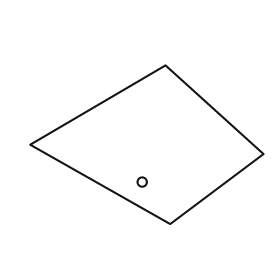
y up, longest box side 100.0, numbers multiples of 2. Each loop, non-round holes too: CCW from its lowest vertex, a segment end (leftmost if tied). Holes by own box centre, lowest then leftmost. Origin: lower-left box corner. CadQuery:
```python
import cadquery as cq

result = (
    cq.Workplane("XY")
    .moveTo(60.0, 0.0)
    .lineTo(100.0, 30.0)
    .lineTo(58.0, 68.0)
    .lineTo(0.0, 34.0)
    .close()
    .moveTo(48.0, 18.0)
    .circle(2.0)
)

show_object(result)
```